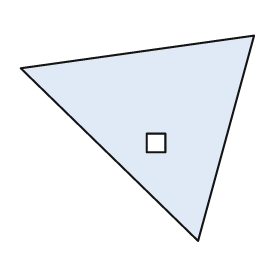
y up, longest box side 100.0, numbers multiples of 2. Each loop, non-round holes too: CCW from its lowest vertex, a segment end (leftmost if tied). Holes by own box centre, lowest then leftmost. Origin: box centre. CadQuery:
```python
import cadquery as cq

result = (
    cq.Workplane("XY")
    .moveTo(26.0, -44.0)
    .lineTo(50.0, 44.0)
    .lineTo(-50.0, 30.0)
    .close()
    .moveTo(4.0, -6.0)
    .lineTo(12.0, -6.0)
    .lineTo(12.0, 2.0)
    .lineTo(4.0, 2.0)
    .close()
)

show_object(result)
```